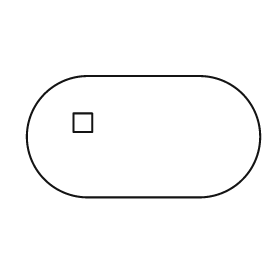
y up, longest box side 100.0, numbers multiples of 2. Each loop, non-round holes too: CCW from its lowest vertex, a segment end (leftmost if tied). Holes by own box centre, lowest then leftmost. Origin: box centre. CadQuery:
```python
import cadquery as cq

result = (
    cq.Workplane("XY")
    .moveTo(-24.0, -26.0)
    .lineTo(24.0, -26.0)
    .threePointArc((50.0, 0.0), (24.0, 26.0))
    .lineTo(-24.0, 26.0)
    .threePointArc((-50.0, 0.0), (-24.0, -26.0))
    .close()
    .moveTo(-30.0, 2.0)
    .lineTo(-22.0, 2.0)
    .lineTo(-22.0, 10.0)
    .lineTo(-30.0, 10.0)
    .close()
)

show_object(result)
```